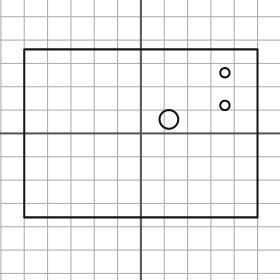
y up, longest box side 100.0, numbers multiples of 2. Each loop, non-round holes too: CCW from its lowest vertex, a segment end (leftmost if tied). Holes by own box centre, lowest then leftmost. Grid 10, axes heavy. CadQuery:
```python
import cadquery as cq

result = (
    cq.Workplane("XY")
    .moveTo(-50.0, -36.0)
    .lineTo(50.0, -36.0)
    .lineTo(50.0, 36.0)
    .lineTo(-50.0, 36.0)
    .close()
    .moveTo(12.0, 6.0)
    .circle(4.0)
    .moveTo(36.0, 12.0)
    .circle(2.0)
    .moveTo(36.0, 26.0)
    .circle(2.0)
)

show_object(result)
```